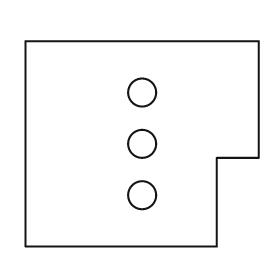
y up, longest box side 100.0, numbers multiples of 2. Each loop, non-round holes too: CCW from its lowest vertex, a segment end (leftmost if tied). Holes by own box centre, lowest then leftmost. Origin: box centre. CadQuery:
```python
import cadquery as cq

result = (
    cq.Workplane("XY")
    .moveTo(-50.0, -44.0)
    .lineTo(32.0, -44.0)
    .lineTo(32.0, -6.0)
    .lineTo(50.0, -6.0)
    .lineTo(50.0, 44.0)
    .lineTo(-50.0, 44.0)
    .close()
    .moveTo(0.0, -22.0)
    .circle(6.0)
    .moveTo(0.0, 0.0)
    .circle(6.0)
    .moveTo(0.0, 22.0)
    .circle(6.0)
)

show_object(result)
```